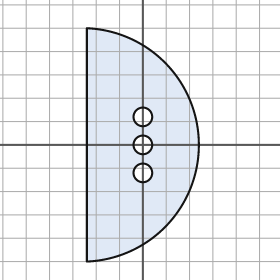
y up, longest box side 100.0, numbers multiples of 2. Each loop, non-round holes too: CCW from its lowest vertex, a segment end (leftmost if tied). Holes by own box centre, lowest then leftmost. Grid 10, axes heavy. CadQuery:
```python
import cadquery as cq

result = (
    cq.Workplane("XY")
    .moveTo(-24.0, -50.0)
    .threePointArc((24.0, 0.0), (-24.0, 50.0))
    .close()
    .moveTo(0.0, -12.0)
    .circle(4.0)
    .moveTo(0.0, 0.0)
    .circle(4.0)
    .moveTo(0.0, 12.0)
    .circle(4.0)
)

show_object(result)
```